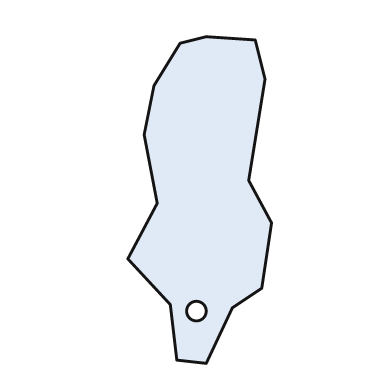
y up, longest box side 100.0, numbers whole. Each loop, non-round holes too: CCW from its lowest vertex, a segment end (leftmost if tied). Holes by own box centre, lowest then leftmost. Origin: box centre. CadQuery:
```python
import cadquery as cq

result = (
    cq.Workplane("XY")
    .moveTo(2.0, -50.0)
    .lineTo(10.0, -33.0)
    .lineTo(19.0, -27.0)
    .lineTo(22.0, -7.0)
    .lineTo(15.0, 6.0)
    .lineTo(20.0, 37.0)
    .lineTo(17.0, 49.0)
    .lineTo(2.0, 50.0)
    .lineTo(-6.0, 48.0)
    .lineTo(-14.0, 35.0)
    .lineTo(-17.0, 20.0)
    .lineTo(-13.0, -1.0)
    .lineTo(-22.0, -18.0)
    .lineTo(-9.0, -32.0)
    .lineTo(-7.0, -49.0)
    .close()
    .moveTo(-1.0, -34.0)
    .circle(3.0)
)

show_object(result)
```